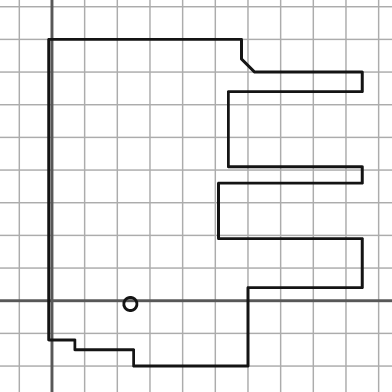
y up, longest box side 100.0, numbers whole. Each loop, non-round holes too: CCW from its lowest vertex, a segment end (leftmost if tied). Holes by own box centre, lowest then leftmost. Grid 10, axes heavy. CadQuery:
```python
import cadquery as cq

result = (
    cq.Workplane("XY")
    .moveTo(25.0, -20.0)
    .lineTo(60.0, -20.0)
    .lineTo(60.0, 4.0)
    .lineTo(95.0, 4.0)
    .lineTo(95.0, 19.0)
    .lineTo(51.0, 19.0)
    .lineTo(51.0, 36.0)
    .lineTo(95.0, 36.0)
    .lineTo(95.0, 41.0)
    .lineTo(54.0, 41.0)
    .lineTo(54.0, 64.0)
    .lineTo(95.0, 64.0)
    .lineTo(95.0, 70.0)
    .lineTo(62.0, 70.0)
    .lineTo(58.0, 74.0)
    .lineTo(58.0, 80.0)
    .lineTo(-1.0, 80.0)
    .lineTo(-1.0, -12.0)
    .lineTo(7.0, -12.0)
    .lineTo(7.0, -15.0)
    .lineTo(25.0, -15.0)
    .close()
    .moveTo(24.0, -1.0)
    .circle(2.0)
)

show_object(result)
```